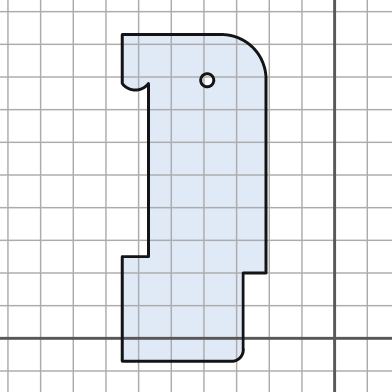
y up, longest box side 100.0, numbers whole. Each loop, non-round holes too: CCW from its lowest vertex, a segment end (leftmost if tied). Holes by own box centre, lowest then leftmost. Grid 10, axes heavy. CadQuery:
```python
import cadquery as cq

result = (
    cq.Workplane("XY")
    .moveTo(-65.0, -7.0)
    .lineTo(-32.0, -7.0)
    .threePointArc((-29.0, -6.0), (-28.0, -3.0))
    .lineTo(-28.0, 20.0)
    .lineTo(-21.0, 20.0)
    .lineTo(-21.0, 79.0)
    .threePointArc((-25.0, 89.0), (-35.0, 93.0))
    .lineTo(-65.0, 93.0)
    .lineTo(-65.0, 78.0)
    .threePointArc((-61.0, 76.0), (-57.0, 78.0))
    .lineTo(-57.0, 25.0)
    .lineTo(-65.0, 25.0)
    .close()
    .moveTo(-39.0, 79.0)
    .circle(2.0)
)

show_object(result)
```